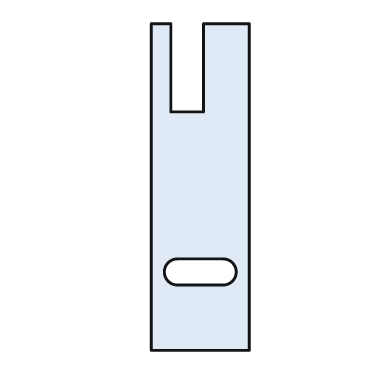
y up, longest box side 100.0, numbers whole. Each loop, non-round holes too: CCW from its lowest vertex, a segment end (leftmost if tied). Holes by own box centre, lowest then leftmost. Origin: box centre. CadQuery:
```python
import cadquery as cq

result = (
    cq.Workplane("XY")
    .moveTo(-15.0, -50.0)
    .lineTo(15.0, -50.0)
    .lineTo(15.0, 50.0)
    .lineTo(1.0, 50.0)
    .lineTo(1.0, 23.0)
    .lineTo(-9.0, 23.0)
    .lineTo(-9.0, 50.0)
    .lineTo(-15.0, 50.0)
    .close()
    .moveTo(-7.0, -30.0)
    .lineTo(7.0, -30.0)
    .threePointArc((11.0, -26.0), (7.0, -22.0))
    .lineTo(-7.0, -22.0)
    .threePointArc((-11.0, -26.0), (-7.0, -30.0))
    .close()
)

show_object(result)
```